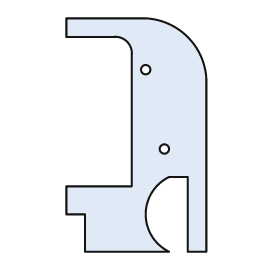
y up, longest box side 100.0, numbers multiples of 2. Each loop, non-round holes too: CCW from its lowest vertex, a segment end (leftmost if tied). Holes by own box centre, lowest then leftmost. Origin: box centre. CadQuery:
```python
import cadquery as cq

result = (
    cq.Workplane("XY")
    .moveTo(-22.0, -50.0)
    .lineTo(14.0, -50.0)
    .threePointArc((4.0, -34.0), (14.0, -18.0))
    .lineTo(22.0, -18.0)
    .lineTo(22.0, -50.0)
    .lineTo(30.0, -50.0)
    .lineTo(30.0, 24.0)
    .threePointArc((22.0, 42.0), (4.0, 50.0))
    .lineTo(-30.0, 50.0)
    .lineTo(-30.0, 42.0)
    .lineTo(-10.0, 42.0)
    .threePointArc((-4.0, 40.0), (-2.0, 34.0))
    .lineTo(-2.0, -22.0)
    .lineTo(-30.0, -22.0)
    .lineTo(-30.0, -34.0)
    .lineTo(-22.0, -34.0)
    .close()
    .moveTo(12.0, -6.0)
    .circle(2.0)
    .moveTo(4.0, 28.0)
    .circle(2.0)
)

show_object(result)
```